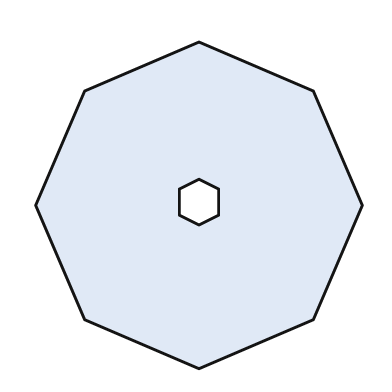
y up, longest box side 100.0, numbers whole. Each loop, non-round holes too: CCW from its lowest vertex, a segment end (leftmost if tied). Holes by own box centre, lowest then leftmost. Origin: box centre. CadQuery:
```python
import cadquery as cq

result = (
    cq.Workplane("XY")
    .moveTo(0.0, -50.0)
    .lineTo(35.0, -35.0)
    .lineTo(50.0, 0.0)
    .lineTo(35.0, 35.0)
    .lineTo(0.0, 50.0)
    .lineTo(-35.0, 35.0)
    .lineTo(-50.0, 0.0)
    .lineTo(-35.0, -35.0)
    .close()
    .moveTo(0.0, -6.0)
    .lineTo(6.0, -3.0)
    .lineTo(6.0, 5.0)
    .lineTo(0.0, 8.0)
    .lineTo(-6.0, 5.0)
    .lineTo(-6.0, -3.0)
    .close()
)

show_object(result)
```